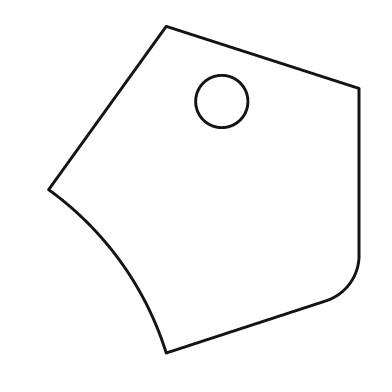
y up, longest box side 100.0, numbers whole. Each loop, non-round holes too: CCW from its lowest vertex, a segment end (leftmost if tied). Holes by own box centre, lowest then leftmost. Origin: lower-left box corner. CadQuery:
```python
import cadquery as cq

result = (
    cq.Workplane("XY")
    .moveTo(36.0, 0.0)
    .lineTo(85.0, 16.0)
    .threePointArc((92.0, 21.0), (95.0, 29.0))
    .lineTo(95.0, 81.0)
    .lineTo(36.0, 100.0)
    .lineTo(0.0, 50.0)
    .threePointArc((22.0, 28.0), (36.0, 0.0))
    .close()
    .moveTo(53.0, 77.0)
    .circle(8.0)
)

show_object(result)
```